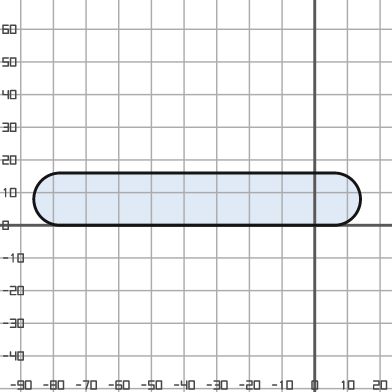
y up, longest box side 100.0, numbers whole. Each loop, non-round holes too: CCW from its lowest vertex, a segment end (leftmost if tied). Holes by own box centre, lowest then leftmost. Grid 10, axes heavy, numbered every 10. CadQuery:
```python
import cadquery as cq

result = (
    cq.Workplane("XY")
    .moveTo(-78.0, 0.0)
    .lineTo(6.0, 0.0)
    .threePointArc((14.0, 8.0), (6.0, 16.0))
    .lineTo(-78.0, 16.0)
    .threePointArc((-86.0, 8.0), (-78.0, 0.0))
    .close()
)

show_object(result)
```